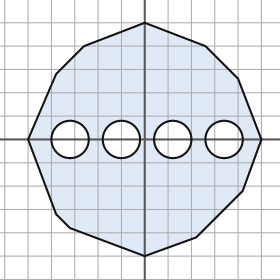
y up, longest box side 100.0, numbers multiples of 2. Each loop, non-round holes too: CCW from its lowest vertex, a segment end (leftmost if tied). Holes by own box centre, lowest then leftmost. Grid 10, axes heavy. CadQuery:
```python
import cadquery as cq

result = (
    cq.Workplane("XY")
    .moveTo(0.0, -50.0)
    .lineTo(22.0, -42.0)
    .lineTo(42.0, -22.0)
    .lineTo(50.0, 0.0)
    .lineTo(40.0, 26.0)
    .lineTo(26.0, 40.0)
    .lineTo(0.0, 50.0)
    .lineTo(-26.0, 40.0)
    .lineTo(-38.0, 28.0)
    .lineTo(-50.0, 0.0)
    .lineTo(-38.0, -32.0)
    .lineTo(-32.0, -38.0)
    .close()
    .moveTo(-32.0, 0.0)
    .circle(8.0)
    .moveTo(-10.0, 0.0)
    .circle(8.0)
    .moveTo(12.0, 0.0)
    .circle(8.0)
    .moveTo(34.0, 0.0)
    .circle(8.0)
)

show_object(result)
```